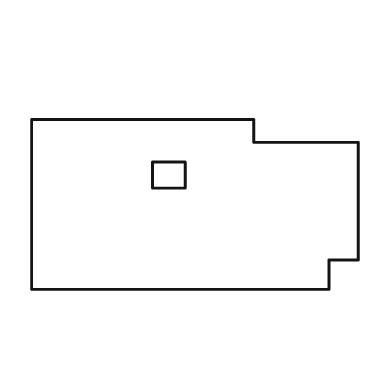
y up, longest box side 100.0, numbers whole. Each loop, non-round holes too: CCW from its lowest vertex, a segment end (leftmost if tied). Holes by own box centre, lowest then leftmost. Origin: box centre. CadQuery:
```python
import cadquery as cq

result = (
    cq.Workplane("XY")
    .moveTo(-50.0, -26.0)
    .lineTo(41.0, -26.0)
    .lineTo(41.0, -17.0)
    .lineTo(50.0, -17.0)
    .lineTo(50.0, 19.0)
    .lineTo(18.0, 19.0)
    .lineTo(18.0, 26.0)
    .lineTo(-50.0, 26.0)
    .close()
    .moveTo(-13.0, 5.0)
    .lineTo(-3.0, 5.0)
    .lineTo(-3.0, 13.0)
    .lineTo(-13.0, 13.0)
    .close()
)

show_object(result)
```